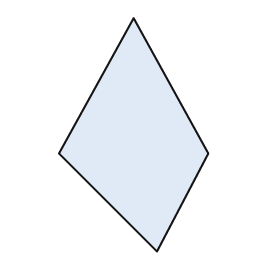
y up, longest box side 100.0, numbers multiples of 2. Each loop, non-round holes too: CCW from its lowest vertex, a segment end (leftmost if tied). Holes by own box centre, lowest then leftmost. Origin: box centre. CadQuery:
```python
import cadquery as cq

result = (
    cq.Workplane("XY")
    .moveTo(10.0, -50.0)
    .lineTo(32.0, -8.0)
    .lineTo(0.0, 50.0)
    .lineTo(-32.0, -8.0)
    .close()
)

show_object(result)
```